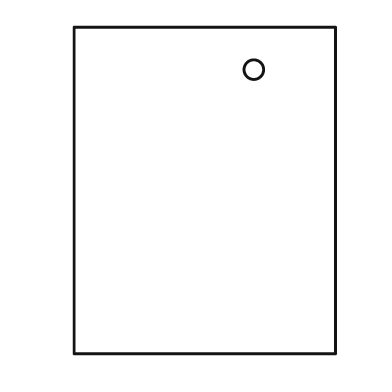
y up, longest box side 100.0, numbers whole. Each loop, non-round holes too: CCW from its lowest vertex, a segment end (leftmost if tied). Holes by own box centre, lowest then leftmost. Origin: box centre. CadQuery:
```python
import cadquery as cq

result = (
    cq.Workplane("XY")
    .moveTo(-40.0, -50.0)
    .lineTo(40.0, -50.0)
    .lineTo(40.0, 50.0)
    .lineTo(-40.0, 50.0)
    .close()
    .moveTo(15.0, 37.0)
    .circle(3.0)
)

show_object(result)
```